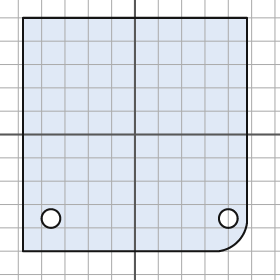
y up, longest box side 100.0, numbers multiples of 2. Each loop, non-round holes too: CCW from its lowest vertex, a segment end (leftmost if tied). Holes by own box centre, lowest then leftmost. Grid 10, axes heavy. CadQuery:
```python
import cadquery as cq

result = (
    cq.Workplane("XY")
    .moveTo(-48.0, -50.0)
    .lineTo(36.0, -50.0)
    .threePointArc((44.0, -46.0), (48.0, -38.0))
    .lineTo(48.0, 50.0)
    .lineTo(-48.0, 50.0)
    .close()
    .moveTo(-36.0, -36.0)
    .circle(4.0)
    .moveTo(40.0, -36.0)
    .circle(4.0)
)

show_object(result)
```